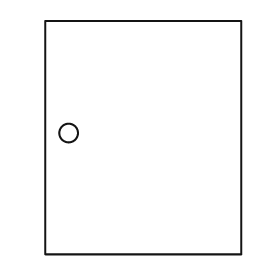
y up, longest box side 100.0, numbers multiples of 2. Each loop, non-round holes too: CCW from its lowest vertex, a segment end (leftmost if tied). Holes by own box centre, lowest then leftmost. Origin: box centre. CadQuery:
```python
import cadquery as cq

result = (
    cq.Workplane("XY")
    .moveTo(-42.0, -50.0)
    .lineTo(42.0, -50.0)
    .lineTo(42.0, 50.0)
    .lineTo(-42.0, 50.0)
    .close()
    .moveTo(-32.0, 2.0)
    .circle(4.0)
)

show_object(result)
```